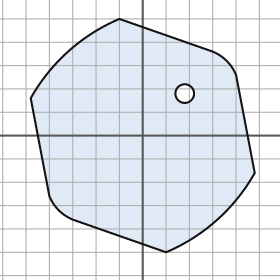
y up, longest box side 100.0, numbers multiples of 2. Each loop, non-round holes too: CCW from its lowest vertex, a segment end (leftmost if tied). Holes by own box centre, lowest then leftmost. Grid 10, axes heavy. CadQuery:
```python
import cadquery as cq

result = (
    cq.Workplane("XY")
    .moveTo(10.0, -50.0)
    .threePointArc((32.0, -36.0), (48.0, -16.0))
    .lineTo(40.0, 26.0)
    .threePointArc((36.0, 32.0), (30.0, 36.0))
    .lineTo(-10.0, 50.0)
    .threePointArc((-32.0, 36.0), (-48.0, 16.0))
    .lineTo(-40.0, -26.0)
    .threePointArc((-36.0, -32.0), (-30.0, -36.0))
    .close()
    .moveTo(18.0, 18.0)
    .circle(4.0)
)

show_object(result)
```